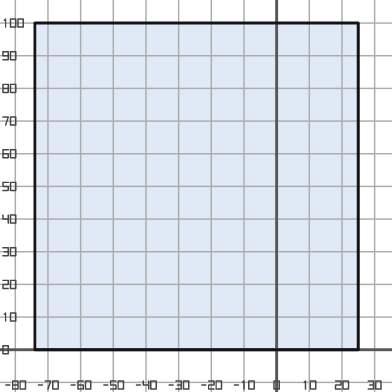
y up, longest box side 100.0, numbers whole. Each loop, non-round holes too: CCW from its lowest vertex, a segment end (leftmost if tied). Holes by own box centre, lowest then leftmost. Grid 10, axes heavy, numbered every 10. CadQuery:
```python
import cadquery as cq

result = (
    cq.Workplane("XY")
    .moveTo(-74.0, 0.0)
    .lineTo(25.0, 0.0)
    .lineTo(25.0, 100.0)
    .lineTo(-74.0, 100.0)
    .close()
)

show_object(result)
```